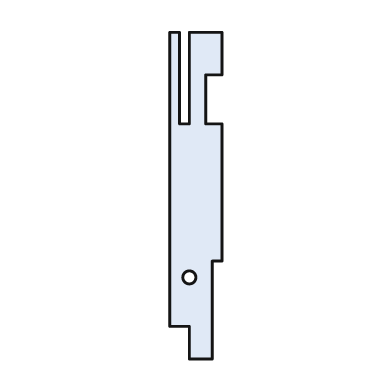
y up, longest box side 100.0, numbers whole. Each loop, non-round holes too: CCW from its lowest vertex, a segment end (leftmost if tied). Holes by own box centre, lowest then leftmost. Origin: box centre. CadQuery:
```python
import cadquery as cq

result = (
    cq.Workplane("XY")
    .moveTo(-2.0, -50.0)
    .lineTo(5.0, -50.0)
    .lineTo(5.0, -20.0)
    .lineTo(8.0, -20.0)
    .lineTo(8.0, 22.0)
    .lineTo(3.0, 22.0)
    .lineTo(3.0, 37.0)
    .lineTo(8.0, 37.0)
    .lineTo(8.0, 50.0)
    .lineTo(-2.0, 50.0)
    .lineTo(-2.0, 22.0)
    .lineTo(-5.0, 22.0)
    .lineTo(-5.0, 50.0)
    .lineTo(-8.0, 50.0)
    .lineTo(-8.0, -40.0)
    .lineTo(-2.0, -40.0)
    .close()
    .moveTo(-2.0, -25.0)
    .circle(2.0)
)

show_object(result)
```